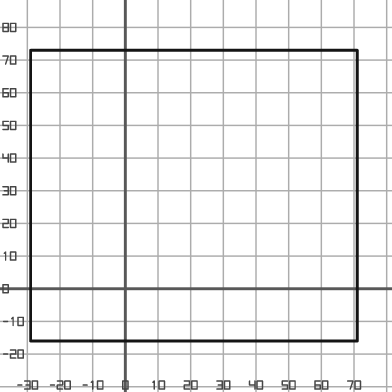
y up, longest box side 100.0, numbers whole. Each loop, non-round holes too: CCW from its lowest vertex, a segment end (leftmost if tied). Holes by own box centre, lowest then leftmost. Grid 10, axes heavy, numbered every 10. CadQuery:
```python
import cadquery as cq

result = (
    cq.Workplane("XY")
    .moveTo(-29.0, -16.0)
    .lineTo(71.0, -16.0)
    .lineTo(71.0, 73.0)
    .lineTo(-29.0, 73.0)
    .close()
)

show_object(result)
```